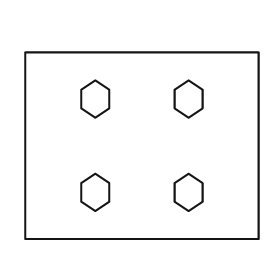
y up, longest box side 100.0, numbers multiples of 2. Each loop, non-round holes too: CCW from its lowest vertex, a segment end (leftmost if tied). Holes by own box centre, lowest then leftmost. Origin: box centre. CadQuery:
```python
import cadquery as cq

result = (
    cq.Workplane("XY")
    .moveTo(-50.0, -40.0)
    .lineTo(50.0, -40.0)
    .lineTo(50.0, 40.0)
    .lineTo(-50.0, 40.0)
    .close()
    .moveTo(-20.0, -28.0)
    .lineTo(-14.0, -24.0)
    .lineTo(-14.0, -16.0)
    .lineTo(-20.0, -12.0)
    .lineTo(-26.0, -16.0)
    .lineTo(-26.0, -24.0)
    .close()
    .moveTo(20.0, -28.0)
    .lineTo(26.0, -24.0)
    .lineTo(26.0, -16.0)
    .lineTo(20.0, -12.0)
    .lineTo(14.0, -16.0)
    .lineTo(14.0, -24.0)
    .close()
    .moveTo(-20.0, 12.0)
    .lineTo(-14.0, 16.0)
    .lineTo(-14.0, 24.0)
    .lineTo(-20.0, 28.0)
    .lineTo(-26.0, 24.0)
    .lineTo(-26.0, 16.0)
    .close()
    .moveTo(20.0, 12.0)
    .lineTo(26.0, 16.0)
    .lineTo(26.0, 24.0)
    .lineTo(20.0, 28.0)
    .lineTo(14.0, 24.0)
    .lineTo(14.0, 16.0)
    .close()
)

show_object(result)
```